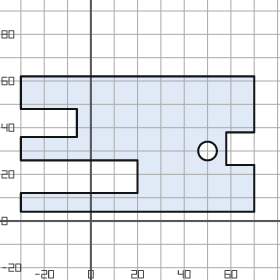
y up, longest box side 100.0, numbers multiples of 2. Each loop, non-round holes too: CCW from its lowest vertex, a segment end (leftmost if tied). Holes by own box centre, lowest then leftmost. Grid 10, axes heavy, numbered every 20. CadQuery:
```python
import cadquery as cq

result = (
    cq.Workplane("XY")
    .moveTo(-30.0, 4.0)
    .lineTo(70.0, 4.0)
    .lineTo(70.0, 24.0)
    .lineTo(58.0, 24.0)
    .lineTo(58.0, 38.0)
    .lineTo(70.0, 38.0)
    .lineTo(70.0, 62.0)
    .lineTo(-30.0, 62.0)
    .lineTo(-30.0, 48.0)
    .lineTo(-6.0, 48.0)
    .lineTo(-6.0, 36.0)
    .lineTo(-30.0, 36.0)
    .lineTo(-30.0, 26.0)
    .lineTo(20.0, 26.0)
    .lineTo(20.0, 12.0)
    .lineTo(-30.0, 12.0)
    .close()
    .moveTo(50.0, 30.0)
    .circle(4.0)
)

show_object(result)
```